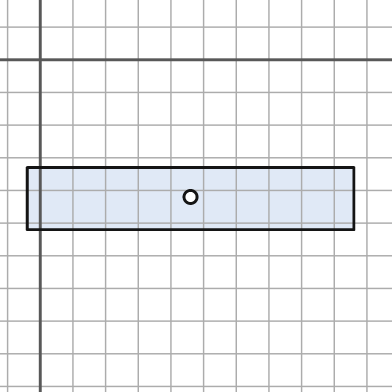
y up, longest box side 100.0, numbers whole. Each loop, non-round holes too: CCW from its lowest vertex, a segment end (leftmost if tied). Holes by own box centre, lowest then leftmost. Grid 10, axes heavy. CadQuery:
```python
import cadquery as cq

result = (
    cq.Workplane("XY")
    .moveTo(-4.0, -52.0)
    .lineTo(96.0, -52.0)
    .lineTo(96.0, -33.0)
    .lineTo(-4.0, -33.0)
    .close()
    .moveTo(46.0, -42.0)
    .circle(2.0)
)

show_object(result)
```